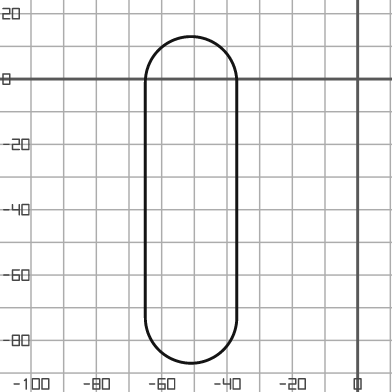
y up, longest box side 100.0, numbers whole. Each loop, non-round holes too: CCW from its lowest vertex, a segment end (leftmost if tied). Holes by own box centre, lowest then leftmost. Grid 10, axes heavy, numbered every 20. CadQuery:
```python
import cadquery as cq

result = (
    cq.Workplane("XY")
    .moveTo(-65.0, -73.0)
    .threePointArc((-51.0, -87.0), (-37.0, -73.0))
    .lineTo(-37.0, -1.0)
    .threePointArc((-51.0, 13.0), (-65.0, -1.0))
    .close()
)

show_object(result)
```